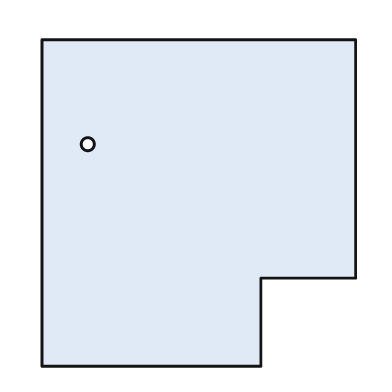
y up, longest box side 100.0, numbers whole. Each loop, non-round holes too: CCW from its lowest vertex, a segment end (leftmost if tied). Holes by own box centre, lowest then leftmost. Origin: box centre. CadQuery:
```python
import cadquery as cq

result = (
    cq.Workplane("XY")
    .moveTo(-48.0, -50.0)
    .lineTo(19.0, -50.0)
    .lineTo(19.0, -23.0)
    .lineTo(48.0, -23.0)
    .lineTo(48.0, 50.0)
    .lineTo(-48.0, 50.0)
    .close()
    .moveTo(-34.0, 18.0)
    .circle(2.0)
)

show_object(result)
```